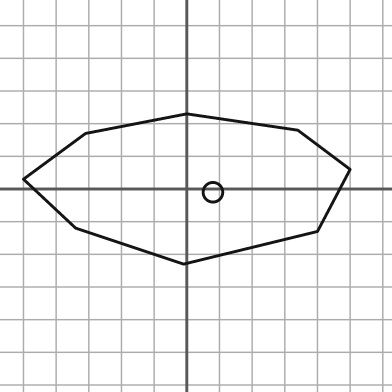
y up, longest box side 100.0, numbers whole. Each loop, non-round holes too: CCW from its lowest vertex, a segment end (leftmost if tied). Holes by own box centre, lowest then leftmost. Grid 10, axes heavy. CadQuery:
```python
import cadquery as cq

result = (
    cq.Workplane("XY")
    .moveTo(-1.0, -23.0)
    .lineTo(40.0, -13.0)
    .lineTo(50.0, 6.0)
    .lineTo(34.0, 18.0)
    .lineTo(0.0, 23.0)
    .lineTo(-31.0, 17.0)
    .lineTo(-50.0, 3.0)
    .lineTo(-34.0, -12.0)
    .close()
    .moveTo(8.0, -1.0)
    .circle(3.0)
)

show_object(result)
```